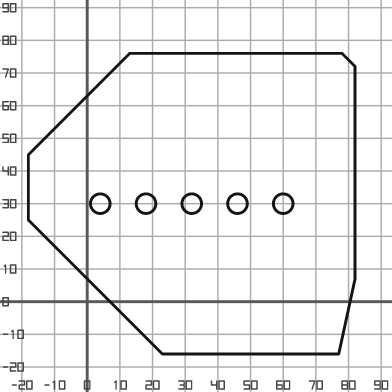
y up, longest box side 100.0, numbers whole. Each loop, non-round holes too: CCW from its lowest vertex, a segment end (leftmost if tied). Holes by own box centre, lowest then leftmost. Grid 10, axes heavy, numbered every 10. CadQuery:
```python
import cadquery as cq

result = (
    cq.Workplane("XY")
    .moveTo(23.0, -16.0)
    .lineTo(77.0, -16.0)
    .lineTo(82.0, 7.0)
    .lineTo(82.0, 72.0)
    .lineTo(78.0, 76.0)
    .lineTo(13.0, 76.0)
    .lineTo(-18.0, 45.0)
    .lineTo(-18.0, 25.0)
    .close()
    .moveTo(4.0, 30.0)
    .circle(3.0)
    .moveTo(18.0, 30.0)
    .circle(3.0)
    .moveTo(32.0, 30.0)
    .circle(3.0)
    .moveTo(46.0, 30.0)
    .circle(3.0)
    .moveTo(60.0, 30.0)
    .circle(3.0)
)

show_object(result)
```